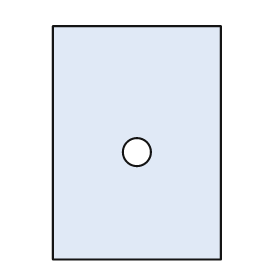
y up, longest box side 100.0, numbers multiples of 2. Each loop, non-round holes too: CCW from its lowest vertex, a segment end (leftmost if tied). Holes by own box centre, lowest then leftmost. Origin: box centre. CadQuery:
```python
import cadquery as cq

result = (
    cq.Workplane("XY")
    .moveTo(-36.0, -50.0)
    .lineTo(36.0, -50.0)
    .lineTo(36.0, 50.0)
    .lineTo(-36.0, 50.0)
    .close()
    .moveTo(0.0, -4.0)
    .circle(6.0)
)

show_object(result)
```